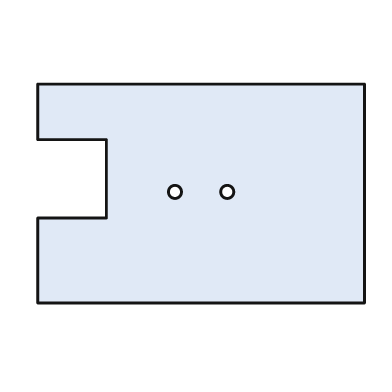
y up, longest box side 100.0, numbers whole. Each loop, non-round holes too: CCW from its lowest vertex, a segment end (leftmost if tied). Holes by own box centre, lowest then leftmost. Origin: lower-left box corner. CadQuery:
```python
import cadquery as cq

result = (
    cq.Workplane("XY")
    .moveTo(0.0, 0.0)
    .lineTo(100.0, 0.0)
    .lineTo(100.0, 67.0)
    .lineTo(0.0, 67.0)
    .lineTo(0.0, 50.0)
    .lineTo(21.0, 50.0)
    .lineTo(21.0, 26.0)
    .lineTo(0.0, 26.0)
    .close()
    .moveTo(42.0, 34.0)
    .circle(2.0)
    .moveTo(58.0, 34.0)
    .circle(2.0)
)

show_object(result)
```